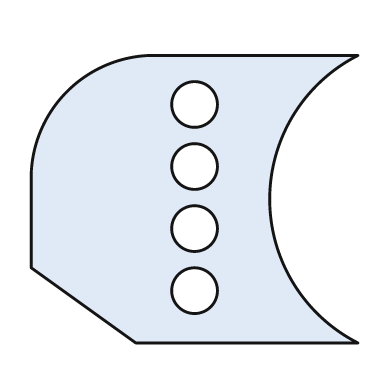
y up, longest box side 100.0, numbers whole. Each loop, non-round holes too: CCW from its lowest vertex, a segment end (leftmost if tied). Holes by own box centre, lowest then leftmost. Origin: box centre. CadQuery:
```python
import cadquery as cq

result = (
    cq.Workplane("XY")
    .moveTo(-18.0, -44.0)
    .lineTo(50.0, -44.0)
    .threePointArc((23.0, 0.0), (50.0, 44.0))
    .lineTo(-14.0, 44.0)
    .threePointArc((-39.0, 33.0), (-50.0, 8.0))
    .lineTo(-50.0, -21.0)
    .close()
    .moveTo(0.0, -28.0)
    .circle(7.0)
    .moveTo(0.0, -9.0)
    .circle(7.0)
    .moveTo(0.0, 10.0)
    .circle(7.0)
    .moveTo(0.0, 29.0)
    .circle(7.0)
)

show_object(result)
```